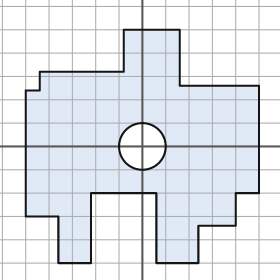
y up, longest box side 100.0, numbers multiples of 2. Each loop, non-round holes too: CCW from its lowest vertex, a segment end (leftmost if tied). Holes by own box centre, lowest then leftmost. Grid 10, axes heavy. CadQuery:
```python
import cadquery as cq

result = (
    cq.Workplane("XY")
    .moveTo(-36.0, -50.0)
    .lineTo(-22.0, -50.0)
    .lineTo(-22.0, -20.0)
    .lineTo(6.0, -20.0)
    .lineTo(6.0, -50.0)
    .lineTo(24.0, -50.0)
    .lineTo(24.0, -34.0)
    .lineTo(40.0, -34.0)
    .lineTo(40.0, -20.0)
    .lineTo(50.0, -20.0)
    .lineTo(50.0, 26.0)
    .lineTo(16.0, 26.0)
    .lineTo(16.0, 50.0)
    .lineTo(-8.0, 50.0)
    .lineTo(-8.0, 32.0)
    .lineTo(-44.0, 32.0)
    .lineTo(-44.0, 24.0)
    .lineTo(-50.0, 24.0)
    .lineTo(-50.0, -30.0)
    .lineTo(-36.0, -30.0)
    .close()
    .moveTo(0.0, 0.0)
    .circle(10.0)
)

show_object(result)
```